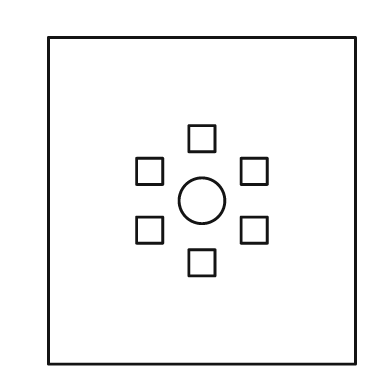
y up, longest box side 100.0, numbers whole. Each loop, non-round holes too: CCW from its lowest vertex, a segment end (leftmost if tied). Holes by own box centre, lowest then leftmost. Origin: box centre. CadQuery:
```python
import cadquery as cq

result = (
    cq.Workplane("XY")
    .moveTo(-47.0, -50.0)
    .lineTo(47.0, -50.0)
    .lineTo(47.0, 50.0)
    .lineTo(-47.0, 50.0)
    .close()
    .moveTo(-4.0, -23.0)
    .lineTo(4.0, -23.0)
    .lineTo(4.0, -15.0)
    .lineTo(-4.0, -15.0)
    .close()
    .moveTo(-20.0, -13.0)
    .lineTo(-12.0, -13.0)
    .lineTo(-12.0, -5.0)
    .lineTo(-20.0, -5.0)
    .close()
    .moveTo(12.0, -13.0)
    .lineTo(20.0, -13.0)
    .lineTo(20.0, -5.0)
    .lineTo(12.0, -5.0)
    .close()
    .moveTo(0.0, 0.0)
    .circle(7.0)
    .moveTo(-20.0, 5.0)
    .lineTo(-12.0, 5.0)
    .lineTo(-12.0, 13.0)
    .lineTo(-20.0, 13.0)
    .close()
    .moveTo(12.0, 5.0)
    .lineTo(20.0, 5.0)
    .lineTo(20.0, 13.0)
    .lineTo(12.0, 13.0)
    .close()
    .moveTo(-4.0, 15.0)
    .lineTo(4.0, 15.0)
    .lineTo(4.0, 23.0)
    .lineTo(-4.0, 23.0)
    .close()
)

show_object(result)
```